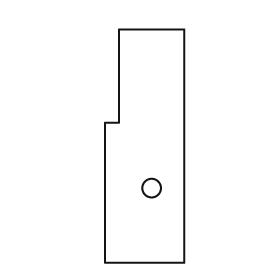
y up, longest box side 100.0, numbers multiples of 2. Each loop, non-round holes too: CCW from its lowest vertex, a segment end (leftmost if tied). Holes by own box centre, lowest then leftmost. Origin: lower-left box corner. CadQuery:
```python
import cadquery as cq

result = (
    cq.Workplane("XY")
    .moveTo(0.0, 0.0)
    .lineTo(34.0, 0.0)
    .lineTo(34.0, 100.0)
    .lineTo(6.0, 100.0)
    .lineTo(6.0, 60.0)
    .lineTo(0.0, 60.0)
    .close()
    .moveTo(20.0, 32.0)
    .circle(4.0)
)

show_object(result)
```